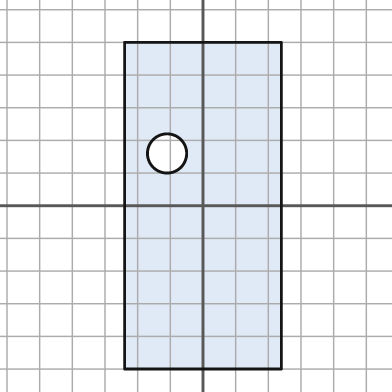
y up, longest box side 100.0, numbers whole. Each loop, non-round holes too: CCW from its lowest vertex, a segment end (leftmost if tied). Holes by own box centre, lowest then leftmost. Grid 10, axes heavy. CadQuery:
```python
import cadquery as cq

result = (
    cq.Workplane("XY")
    .moveTo(-24.0, -50.0)
    .lineTo(24.0, -50.0)
    .lineTo(24.0, 50.0)
    .lineTo(-24.0, 50.0)
    .close()
    .moveTo(-11.0, 16.0)
    .circle(6.0)
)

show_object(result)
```